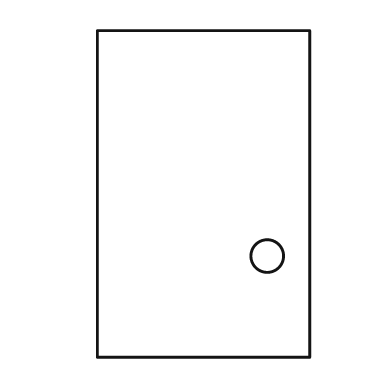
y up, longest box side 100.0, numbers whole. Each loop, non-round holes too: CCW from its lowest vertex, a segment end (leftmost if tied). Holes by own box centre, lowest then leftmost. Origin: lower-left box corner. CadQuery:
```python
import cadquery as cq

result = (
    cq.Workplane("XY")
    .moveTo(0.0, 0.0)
    .lineTo(65.0, 0.0)
    .lineTo(65.0, 100.0)
    .lineTo(0.0, 100.0)
    .close()
    .moveTo(52.0, 31.0)
    .circle(5.0)
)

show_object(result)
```